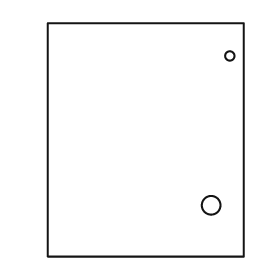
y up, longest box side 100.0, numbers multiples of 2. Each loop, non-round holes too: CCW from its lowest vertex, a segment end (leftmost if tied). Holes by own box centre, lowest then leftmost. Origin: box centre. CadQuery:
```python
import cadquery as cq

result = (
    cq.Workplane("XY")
    .moveTo(-42.0, -50.0)
    .lineTo(42.0, -50.0)
    .lineTo(42.0, 50.0)
    .lineTo(-42.0, 50.0)
    .close()
    .moveTo(28.0, -28.0)
    .circle(4.0)
    .moveTo(36.0, 36.0)
    .circle(2.0)
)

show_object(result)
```